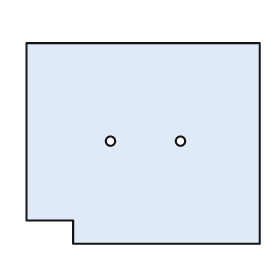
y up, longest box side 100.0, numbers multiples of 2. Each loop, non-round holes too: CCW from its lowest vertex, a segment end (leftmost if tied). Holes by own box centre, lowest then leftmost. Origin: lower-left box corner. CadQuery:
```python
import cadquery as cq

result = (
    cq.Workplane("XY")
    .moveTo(20.0, 0.0)
    .lineTo(100.0, 0.0)
    .lineTo(100.0, 86.0)
    .lineTo(0.0, 86.0)
    .lineTo(0.0, 10.0)
    .lineTo(20.0, 10.0)
    .close()
    .moveTo(36.0, 44.0)
    .circle(2.0)
    .moveTo(66.0, 44.0)
    .circle(2.0)
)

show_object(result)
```